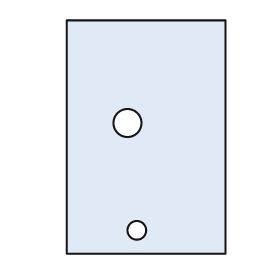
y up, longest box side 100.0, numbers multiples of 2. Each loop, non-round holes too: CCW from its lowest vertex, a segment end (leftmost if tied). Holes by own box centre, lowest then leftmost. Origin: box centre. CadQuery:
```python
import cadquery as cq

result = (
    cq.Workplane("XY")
    .moveTo(-34.0, -50.0)
    .lineTo(34.0, -50.0)
    .lineTo(34.0, 50.0)
    .lineTo(-34.0, 50.0)
    .close()
    .moveTo(-4.0, -40.0)
    .circle(4.0)
    .moveTo(-8.0, 6.0)
    .circle(6.0)
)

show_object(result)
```